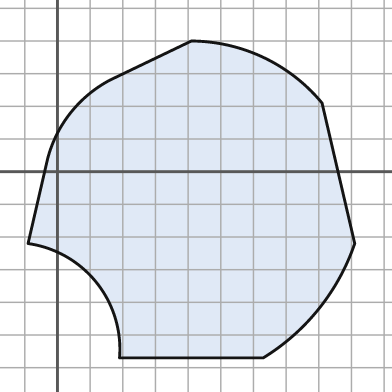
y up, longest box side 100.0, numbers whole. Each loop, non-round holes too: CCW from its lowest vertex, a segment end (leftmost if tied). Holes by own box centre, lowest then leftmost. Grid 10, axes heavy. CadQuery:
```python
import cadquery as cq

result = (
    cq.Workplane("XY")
    .moveTo(19.0, -57.0)
    .lineTo(63.0, -57.0)
    .threePointArc((80.0, -42.0), (91.0, -22.0))
    .lineTo(81.0, 21.0)
    .threePointArc((63.0, 35.0), (41.0, 40.0))
    .lineTo(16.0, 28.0)
    .threePointArc((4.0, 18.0), (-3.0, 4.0))
    .lineTo(-9.0, -22.0)
    .threePointArc((12.0, -34.0), (19.0, -57.0))
    .close()
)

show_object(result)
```